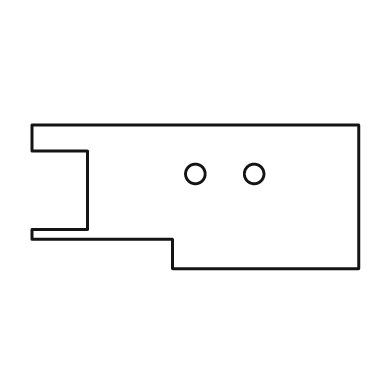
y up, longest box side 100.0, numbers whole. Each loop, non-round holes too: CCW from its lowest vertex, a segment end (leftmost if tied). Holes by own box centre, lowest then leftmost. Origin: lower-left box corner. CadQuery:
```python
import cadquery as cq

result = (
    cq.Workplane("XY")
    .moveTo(43.0, 0.0)
    .lineTo(100.0, 0.0)
    .lineTo(100.0, 44.0)
    .lineTo(0.0, 44.0)
    .lineTo(0.0, 36.0)
    .lineTo(17.0, 36.0)
    .lineTo(17.0, 12.0)
    .lineTo(0.0, 12.0)
    .lineTo(0.0, 9.0)
    .lineTo(43.0, 9.0)
    .close()
    .moveTo(50.0, 29.0)
    .circle(3.0)
    .moveTo(68.0, 29.0)
    .circle(3.0)
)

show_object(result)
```